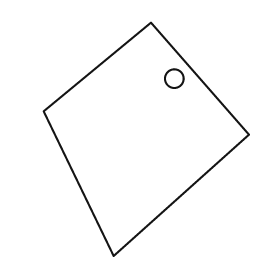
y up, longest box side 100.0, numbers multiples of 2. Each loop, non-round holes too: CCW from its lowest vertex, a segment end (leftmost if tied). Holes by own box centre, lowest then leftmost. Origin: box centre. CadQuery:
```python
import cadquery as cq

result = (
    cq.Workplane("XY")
    .moveTo(-14.0, -50.0)
    .lineTo(44.0, 2.0)
    .lineTo(2.0, 50.0)
    .lineTo(-44.0, 12.0)
    .close()
    .moveTo(12.0, 26.0)
    .circle(4.0)
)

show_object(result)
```